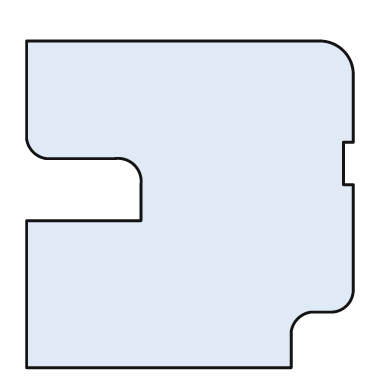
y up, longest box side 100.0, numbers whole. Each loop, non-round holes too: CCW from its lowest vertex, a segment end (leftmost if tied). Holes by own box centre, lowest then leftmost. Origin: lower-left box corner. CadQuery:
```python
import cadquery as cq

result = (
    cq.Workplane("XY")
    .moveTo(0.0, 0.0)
    .lineTo(81.0, 0.0)
    .lineTo(81.0, 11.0)
    .threePointArc((83.0, 15.0), (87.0, 17.0))
    .lineTo(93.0, 17.0)
    .threePointArc((98.0, 19.0), (100.0, 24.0))
    .lineTo(100.0, 56.0)
    .lineTo(97.0, 56.0)
    .lineTo(97.0, 69.0)
    .lineTo(100.0, 69.0)
    .lineTo(100.0, 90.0)
    .threePointArc((97.0, 97.0), (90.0, 100.0))
    .lineTo(0.0, 100.0)
    .lineTo(0.0, 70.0)
    .threePointArc((2.0, 66.0), (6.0, 64.0))
    .lineTo(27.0, 64.0)
    .threePointArc((33.0, 62.0), (35.0, 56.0))
    .lineTo(35.0, 45.0)
    .lineTo(0.0, 45.0)
    .close()
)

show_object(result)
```